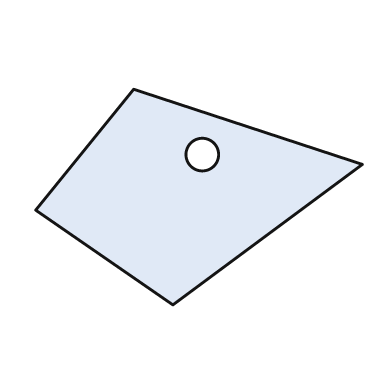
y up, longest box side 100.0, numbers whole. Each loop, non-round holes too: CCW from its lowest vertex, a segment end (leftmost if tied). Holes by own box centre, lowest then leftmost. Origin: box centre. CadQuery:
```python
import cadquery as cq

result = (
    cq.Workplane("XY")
    .moveTo(-8.0, -33.0)
    .lineTo(50.0, 10.0)
    .lineTo(-20.0, 33.0)
    .lineTo(-50.0, -4.0)
    .close()
    .moveTo(1.0, 13.0)
    .circle(5.0)
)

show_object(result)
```